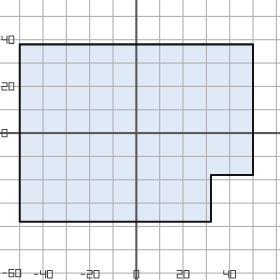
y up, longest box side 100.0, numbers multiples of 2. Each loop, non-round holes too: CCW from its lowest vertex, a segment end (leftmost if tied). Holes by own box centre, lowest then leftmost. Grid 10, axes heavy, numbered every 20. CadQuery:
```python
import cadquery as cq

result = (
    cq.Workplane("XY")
    .moveTo(-50.0, -38.0)
    .lineTo(32.0, -38.0)
    .lineTo(32.0, -18.0)
    .lineTo(50.0, -18.0)
    .lineTo(50.0, 38.0)
    .lineTo(-50.0, 38.0)
    .close()
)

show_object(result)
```